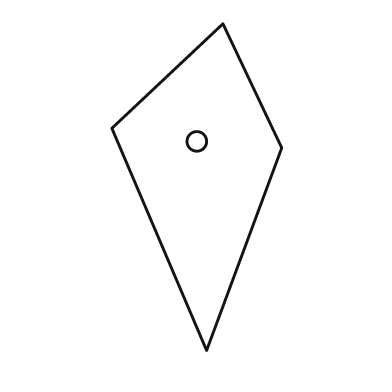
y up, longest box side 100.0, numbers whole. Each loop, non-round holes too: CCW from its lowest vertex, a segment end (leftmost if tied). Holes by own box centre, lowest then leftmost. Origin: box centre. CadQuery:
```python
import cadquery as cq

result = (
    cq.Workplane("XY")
    .moveTo(3.0, -50.0)
    .lineTo(26.0, 12.0)
    .lineTo(8.0, 50.0)
    .lineTo(-26.0, 18.0)
    .close()
    .moveTo(0.0, 14.0)
    .circle(3.0)
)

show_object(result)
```